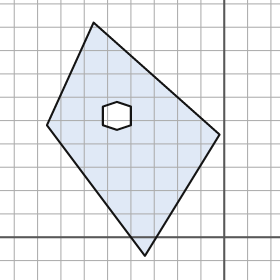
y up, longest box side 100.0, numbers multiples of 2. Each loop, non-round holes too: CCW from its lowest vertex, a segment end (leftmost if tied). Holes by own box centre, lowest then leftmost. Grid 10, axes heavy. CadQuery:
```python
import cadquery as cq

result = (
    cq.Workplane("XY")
    .moveTo(-34.0, -8.0)
    .lineTo(-2.0, 44.0)
    .lineTo(-56.0, 92.0)
    .lineTo(-76.0, 48.0)
    .close()
    .moveTo(-46.0, 46.0)
    .lineTo(-40.0, 48.0)
    .lineTo(-40.0, 56.0)
    .lineTo(-46.0, 58.0)
    .lineTo(-52.0, 56.0)
    .lineTo(-52.0, 48.0)
    .close()
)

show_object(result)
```